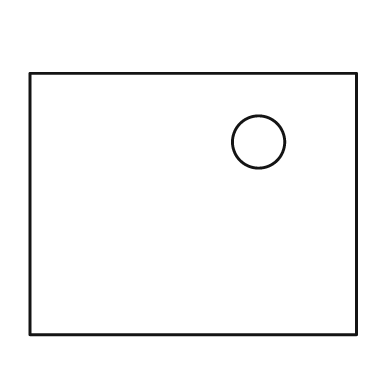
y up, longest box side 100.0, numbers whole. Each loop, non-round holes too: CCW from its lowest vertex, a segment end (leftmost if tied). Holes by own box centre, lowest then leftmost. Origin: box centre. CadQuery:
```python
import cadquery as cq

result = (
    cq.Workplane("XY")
    .moveTo(-50.0, -40.0)
    .lineTo(50.0, -40.0)
    .lineTo(50.0, 40.0)
    .lineTo(-50.0, 40.0)
    .close()
    .moveTo(20.0, 19.0)
    .circle(8.0)
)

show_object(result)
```